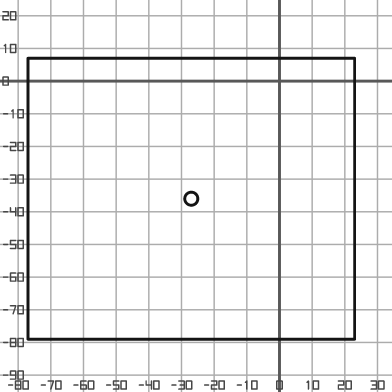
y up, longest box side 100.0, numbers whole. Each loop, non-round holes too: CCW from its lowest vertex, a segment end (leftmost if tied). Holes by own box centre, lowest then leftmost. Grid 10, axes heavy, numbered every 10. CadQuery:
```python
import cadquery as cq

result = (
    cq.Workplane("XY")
    .moveTo(-77.0, -79.0)
    .lineTo(23.0, -79.0)
    .lineTo(23.0, 7.0)
    .lineTo(-77.0, 7.0)
    .close()
    .moveTo(-27.0, -36.0)
    .circle(2.0)
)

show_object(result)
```